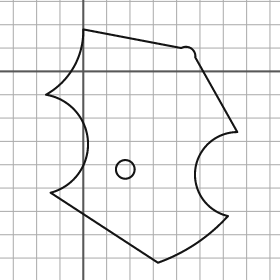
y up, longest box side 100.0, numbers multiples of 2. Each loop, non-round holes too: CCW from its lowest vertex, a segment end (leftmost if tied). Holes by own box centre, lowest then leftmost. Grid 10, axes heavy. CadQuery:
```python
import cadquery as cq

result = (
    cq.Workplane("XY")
    .moveTo(32.0, -82.0)
    .threePointArc((48.0, -74.0), (62.0, -62.0))
    .threePointArc((48.0, -42.0), (66.0, -26.0))
    .lineTo(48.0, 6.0)
    .threePointArc((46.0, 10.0), (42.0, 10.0))
    .lineTo(0.0, 18.0)
    .threePointArc((-4.0, 2.0), (-16.0, -10.0))
    .threePointArc((2.0, -30.0), (-14.0, -52.0))
    .close()
    .moveTo(18.0, -42.0)
    .circle(4.0)
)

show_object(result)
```